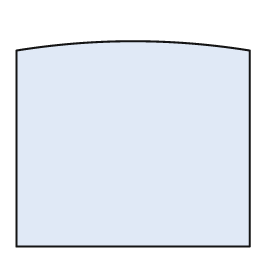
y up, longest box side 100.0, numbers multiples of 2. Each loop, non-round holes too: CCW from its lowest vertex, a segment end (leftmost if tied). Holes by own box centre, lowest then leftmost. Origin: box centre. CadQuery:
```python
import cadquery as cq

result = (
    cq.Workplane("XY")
    .moveTo(-50.0, -44.0)
    .lineTo(50.0, -44.0)
    .lineTo(50.0, 40.0)
    .threePointArc((0.0, 44.0), (-50.0, 40.0))
    .close()
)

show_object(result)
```